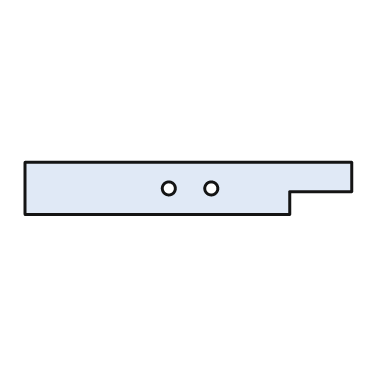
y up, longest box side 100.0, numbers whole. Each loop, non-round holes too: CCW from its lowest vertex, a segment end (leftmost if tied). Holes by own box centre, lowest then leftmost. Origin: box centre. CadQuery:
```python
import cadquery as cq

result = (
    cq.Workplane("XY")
    .moveTo(-50.0, -8.0)
    .lineTo(31.0, -8.0)
    .lineTo(31.0, -1.0)
    .lineTo(50.0, -1.0)
    .lineTo(50.0, 8.0)
    .lineTo(-50.0, 8.0)
    .close()
    .moveTo(-6.0, 0.0)
    .circle(2.0)
    .moveTo(7.0, 0.0)
    .circle(2.0)
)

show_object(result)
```